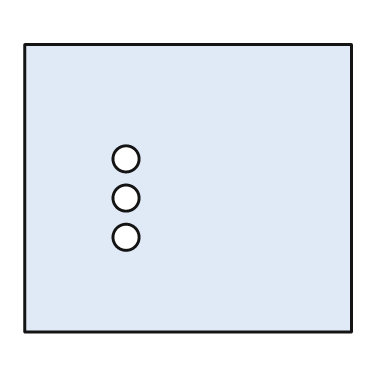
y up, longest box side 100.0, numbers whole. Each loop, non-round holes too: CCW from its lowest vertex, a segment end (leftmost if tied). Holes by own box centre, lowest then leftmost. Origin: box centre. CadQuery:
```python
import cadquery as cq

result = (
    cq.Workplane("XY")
    .moveTo(-50.0, -44.0)
    .lineTo(50.0, -44.0)
    .lineTo(50.0, 44.0)
    .lineTo(-50.0, 44.0)
    .close()
    .moveTo(-19.0, -15.0)
    .circle(4.0)
    .moveTo(-19.0, -3.0)
    .circle(4.0)
    .moveTo(-19.0, 9.0)
    .circle(4.0)
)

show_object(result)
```